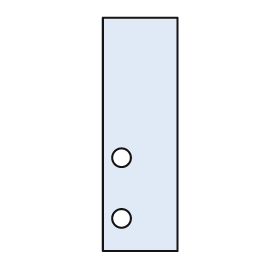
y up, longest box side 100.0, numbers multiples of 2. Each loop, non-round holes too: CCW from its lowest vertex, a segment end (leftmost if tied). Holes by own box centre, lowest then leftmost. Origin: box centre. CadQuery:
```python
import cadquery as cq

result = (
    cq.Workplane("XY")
    .moveTo(-16.0, -50.0)
    .lineTo(16.0, -50.0)
    .lineTo(16.0, 50.0)
    .lineTo(-16.0, 50.0)
    .close()
    .moveTo(-8.0, -36.0)
    .circle(4.0)
    .moveTo(-8.0, -10.0)
    .circle(4.0)
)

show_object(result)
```